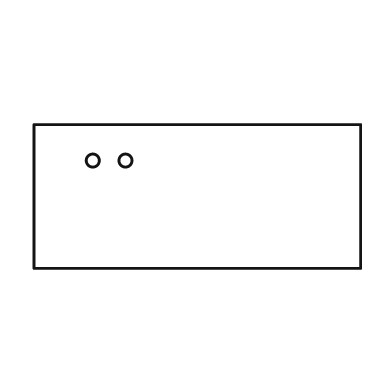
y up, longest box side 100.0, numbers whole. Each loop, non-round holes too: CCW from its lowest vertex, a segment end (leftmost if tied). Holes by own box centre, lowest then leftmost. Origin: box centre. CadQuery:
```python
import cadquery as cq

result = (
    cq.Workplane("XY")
    .moveTo(-50.0, -22.0)
    .lineTo(50.0, -22.0)
    .lineTo(50.0, 22.0)
    .lineTo(-50.0, 22.0)
    .close()
    .moveTo(-32.0, 11.0)
    .circle(2.0)
    .moveTo(-22.0, 11.0)
    .circle(2.0)
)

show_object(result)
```